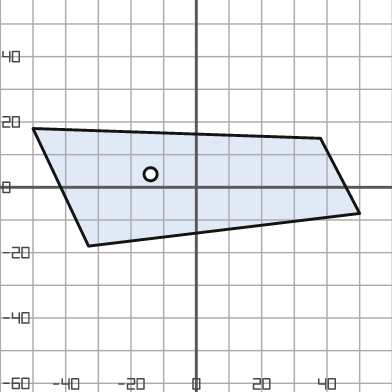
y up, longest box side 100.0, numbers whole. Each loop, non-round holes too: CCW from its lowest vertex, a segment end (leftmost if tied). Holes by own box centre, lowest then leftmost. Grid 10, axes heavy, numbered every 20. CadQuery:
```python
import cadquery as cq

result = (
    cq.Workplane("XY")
    .moveTo(-33.0, -18.0)
    .lineTo(50.0, -8.0)
    .lineTo(38.0, 15.0)
    .lineTo(-50.0, 18.0)
    .close()
    .moveTo(-14.0, 4.0)
    .circle(2.0)
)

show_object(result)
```